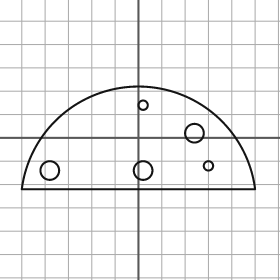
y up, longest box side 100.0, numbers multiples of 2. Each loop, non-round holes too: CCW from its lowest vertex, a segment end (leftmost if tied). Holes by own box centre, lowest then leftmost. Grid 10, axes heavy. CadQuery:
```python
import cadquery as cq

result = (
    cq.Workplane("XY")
    .moveTo(-50.0, -22.0)
    .lineTo(50.0, -22.0)
    .threePointArc((0.0, 22.0), (-50.0, -22.0))
    .close()
    .moveTo(-38.0, -14.0)
    .circle(4.0)
    .moveTo(2.0, -14.0)
    .circle(4.0)
    .moveTo(30.0, -12.0)
    .circle(2.0)
    .moveTo(24.0, 2.0)
    .circle(4.0)
    .moveTo(2.0, 14.0)
    .circle(2.0)
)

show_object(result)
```